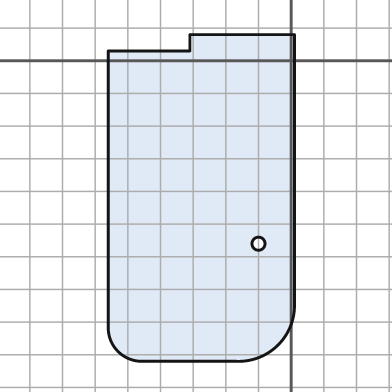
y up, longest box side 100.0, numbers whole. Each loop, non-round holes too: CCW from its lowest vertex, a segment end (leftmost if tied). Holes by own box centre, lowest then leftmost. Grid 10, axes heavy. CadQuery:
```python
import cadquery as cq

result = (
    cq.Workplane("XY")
    .moveTo(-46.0, -92.0)
    .lineTo(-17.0, -92.0)
    .threePointArc((-4.0, -87.0), (1.0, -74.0))
    .lineTo(1.0, 8.0)
    .lineTo(-31.0, 8.0)
    .lineTo(-31.0, 3.0)
    .lineTo(-56.0, 3.0)
    .lineTo(-56.0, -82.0)
    .threePointArc((-53.0, -89.0), (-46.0, -92.0))
    .close()
    .moveTo(-10.0, -56.0)
    .circle(2.0)
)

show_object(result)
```